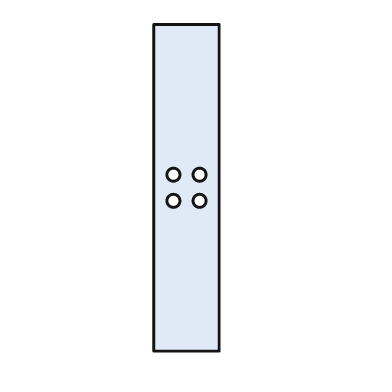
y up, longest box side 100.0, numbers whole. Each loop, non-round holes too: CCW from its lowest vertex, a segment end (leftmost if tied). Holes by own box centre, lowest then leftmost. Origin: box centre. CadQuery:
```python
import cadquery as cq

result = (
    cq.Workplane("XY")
    .moveTo(-10.0, -50.0)
    .lineTo(10.0, -50.0)
    .lineTo(10.0, 50.0)
    .lineTo(-10.0, 50.0)
    .close()
    .moveTo(-4.0, -4.0)
    .circle(2.0)
    .moveTo(4.0, -4.0)
    .circle(2.0)
    .moveTo(-4.0, 4.0)
    .circle(2.0)
    .moveTo(4.0, 4.0)
    .circle(2.0)
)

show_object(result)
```